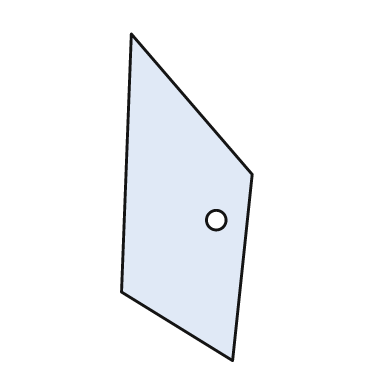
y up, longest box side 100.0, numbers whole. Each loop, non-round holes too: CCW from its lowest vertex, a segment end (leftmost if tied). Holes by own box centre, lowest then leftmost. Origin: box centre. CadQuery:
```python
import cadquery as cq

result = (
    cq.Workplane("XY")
    .moveTo(14.0, -50.0)
    .lineTo(20.0, 7.0)
    .lineTo(-17.0, 50.0)
    .lineTo(-20.0, -29.0)
    .close()
    .moveTo(9.0, -7.0)
    .circle(3.0)
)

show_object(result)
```